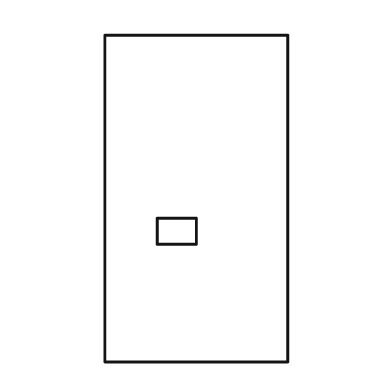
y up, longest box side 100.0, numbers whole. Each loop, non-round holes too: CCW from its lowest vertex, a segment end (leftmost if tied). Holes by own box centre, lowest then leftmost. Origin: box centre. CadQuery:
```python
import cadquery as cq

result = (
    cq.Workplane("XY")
    .moveTo(-28.0, -50.0)
    .lineTo(28.0, -50.0)
    .lineTo(28.0, 50.0)
    .lineTo(-28.0, 50.0)
    .close()
    .moveTo(-12.0, -14.0)
    .lineTo(0.0, -14.0)
    .lineTo(0.0, -6.0)
    .lineTo(-12.0, -6.0)
    .close()
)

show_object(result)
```